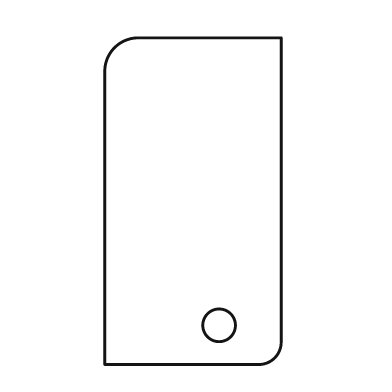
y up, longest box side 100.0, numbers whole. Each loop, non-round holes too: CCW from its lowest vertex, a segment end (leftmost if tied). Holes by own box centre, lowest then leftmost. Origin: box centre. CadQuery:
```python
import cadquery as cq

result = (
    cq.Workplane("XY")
    .moveTo(-27.0, -50.0)
    .lineTo(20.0, -50.0)
    .threePointArc((25.0, -48.0), (27.0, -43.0))
    .lineTo(27.0, 50.0)
    .lineTo(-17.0, 50.0)
    .threePointArc((-24.0, 47.0), (-27.0, 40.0))
    .close()
    .moveTo(8.0, -38.0)
    .circle(5.0)
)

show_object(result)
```